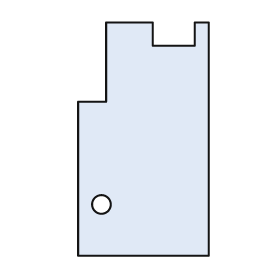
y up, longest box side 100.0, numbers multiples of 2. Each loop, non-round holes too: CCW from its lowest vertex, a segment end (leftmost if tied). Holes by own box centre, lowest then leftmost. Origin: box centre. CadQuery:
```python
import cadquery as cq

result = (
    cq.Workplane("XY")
    .moveTo(-28.0, -50.0)
    .lineTo(28.0, -50.0)
    .lineTo(28.0, 50.0)
    .lineTo(22.0, 50.0)
    .lineTo(22.0, 40.0)
    .lineTo(4.0, 40.0)
    .lineTo(4.0, 50.0)
    .lineTo(-16.0, 50.0)
    .lineTo(-16.0, 16.0)
    .lineTo(-28.0, 16.0)
    .close()
    .moveTo(-18.0, -28.0)
    .circle(4.0)
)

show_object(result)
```